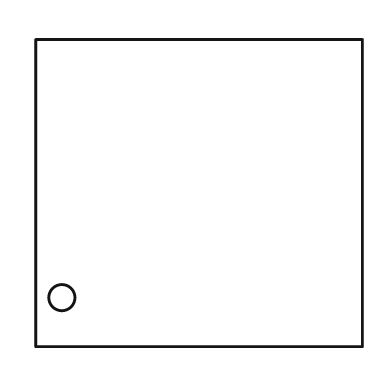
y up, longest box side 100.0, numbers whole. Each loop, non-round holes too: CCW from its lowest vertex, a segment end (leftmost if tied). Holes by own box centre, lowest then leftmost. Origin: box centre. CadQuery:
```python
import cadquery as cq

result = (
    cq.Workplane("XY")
    .moveTo(-50.0, -47.0)
    .lineTo(50.0, -47.0)
    .lineTo(50.0, 47.0)
    .lineTo(-50.0, 47.0)
    .close()
    .moveTo(-42.0, -32.0)
    .circle(4.0)
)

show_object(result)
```